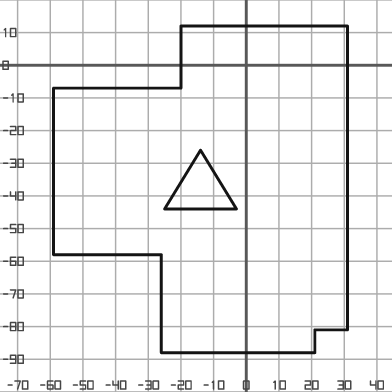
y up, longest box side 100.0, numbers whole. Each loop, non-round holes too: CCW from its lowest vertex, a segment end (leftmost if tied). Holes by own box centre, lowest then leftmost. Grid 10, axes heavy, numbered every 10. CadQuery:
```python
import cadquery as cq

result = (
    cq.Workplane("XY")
    .moveTo(-26.0, -88.0)
    .lineTo(21.0, -88.0)
    .lineTo(21.0, -81.0)
    .lineTo(31.0, -81.0)
    .lineTo(31.0, 12.0)
    .lineTo(-20.0, 12.0)
    .lineTo(-20.0, -7.0)
    .lineTo(-59.0, -7.0)
    .lineTo(-59.0, -58.0)
    .lineTo(-26.0, -58.0)
    .close()
    .moveTo(-25.0, -44.0)
    .lineTo(-3.0, -44.0)
    .lineTo(-14.0, -26.0)
    .close()
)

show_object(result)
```